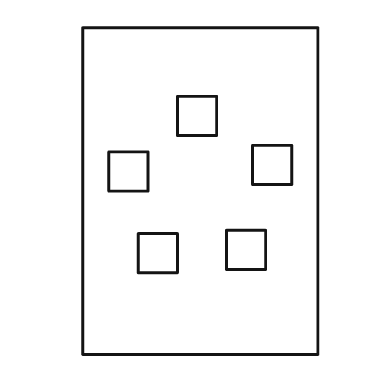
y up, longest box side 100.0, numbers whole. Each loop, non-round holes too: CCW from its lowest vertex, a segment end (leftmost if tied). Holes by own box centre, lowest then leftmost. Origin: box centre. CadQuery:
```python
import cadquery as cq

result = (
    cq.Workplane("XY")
    .moveTo(-36.0, -50.0)
    .lineTo(36.0, -50.0)
    .lineTo(36.0, 50.0)
    .lineTo(-36.0, 50.0)
    .close()
    .moveTo(-19.0, -25.0)
    .lineTo(-7.0, -25.0)
    .lineTo(-7.0, -13.0)
    .lineTo(-19.0, -13.0)
    .close()
    .moveTo(8.0, -24.0)
    .lineTo(20.0, -24.0)
    .lineTo(20.0, -12.0)
    .lineTo(8.0, -12.0)
    .close()
    .moveTo(-28.0, 0.0)
    .lineTo(-16.0, 0.0)
    .lineTo(-16.0, 12.0)
    .lineTo(-28.0, 12.0)
    .close()
    .moveTo(16.0, 2.0)
    .lineTo(28.0, 2.0)
    .lineTo(28.0, 14.0)
    .lineTo(16.0, 14.0)
    .close()
    .moveTo(-7.0, 17.0)
    .lineTo(5.0, 17.0)
    .lineTo(5.0, 29.0)
    .lineTo(-7.0, 29.0)
    .close()
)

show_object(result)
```